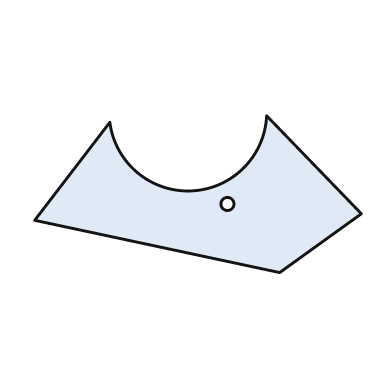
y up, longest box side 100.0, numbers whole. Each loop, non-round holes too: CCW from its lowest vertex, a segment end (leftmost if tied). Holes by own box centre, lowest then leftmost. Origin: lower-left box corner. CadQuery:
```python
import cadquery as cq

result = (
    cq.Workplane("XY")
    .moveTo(75.0, 0.0)
    .lineTo(100.0, 18.0)
    .lineTo(71.0, 48.0)
    .threePointArc((48.0, 25.0), (23.0, 46.0))
    .lineTo(0.0, 16.0)
    .close()
    .moveTo(59.0, 21.0)
    .circle(2.0)
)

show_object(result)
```